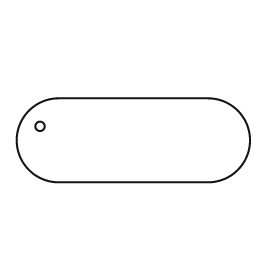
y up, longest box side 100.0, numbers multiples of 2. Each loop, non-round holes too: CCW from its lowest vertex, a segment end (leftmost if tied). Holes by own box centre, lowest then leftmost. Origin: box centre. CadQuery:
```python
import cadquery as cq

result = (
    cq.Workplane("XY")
    .moveTo(-32.0, -18.0)
    .lineTo(32.0, -18.0)
    .threePointArc((50.0, 0.0), (32.0, 18.0))
    .lineTo(-32.0, 18.0)
    .threePointArc((-50.0, 0.0), (-32.0, -18.0))
    .close()
    .moveTo(-40.0, 6.0)
    .circle(2.0)
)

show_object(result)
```